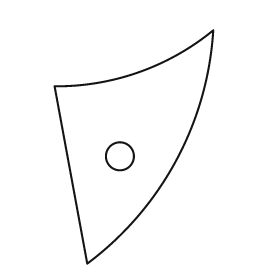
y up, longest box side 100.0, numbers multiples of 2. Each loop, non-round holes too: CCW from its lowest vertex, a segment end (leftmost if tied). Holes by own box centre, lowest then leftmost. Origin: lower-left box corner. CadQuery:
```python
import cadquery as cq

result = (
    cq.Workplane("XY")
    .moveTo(14.0, 0.0)
    .threePointArc((52.0, 44.0), (68.0, 100.0))
    .threePointArc((36.0, 82.0), (0.0, 76.0))
    .close()
    .moveTo(28.0, 46.0)
    .circle(6.0)
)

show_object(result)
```